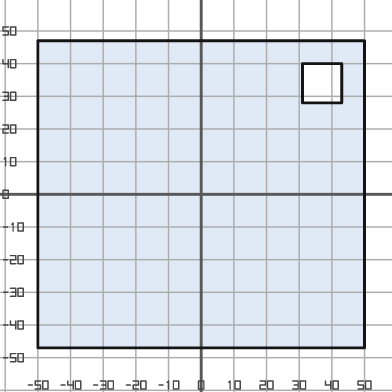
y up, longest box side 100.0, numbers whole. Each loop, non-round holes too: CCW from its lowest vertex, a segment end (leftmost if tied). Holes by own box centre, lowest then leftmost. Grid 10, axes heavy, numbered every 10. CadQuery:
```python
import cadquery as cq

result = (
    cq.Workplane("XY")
    .moveTo(-50.0, -47.0)
    .lineTo(50.0, -47.0)
    .lineTo(50.0, 47.0)
    .lineTo(-50.0, 47.0)
    .close()
    .moveTo(31.0, 28.0)
    .lineTo(43.0, 28.0)
    .lineTo(43.0, 40.0)
    .lineTo(31.0, 40.0)
    .close()
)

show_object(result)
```